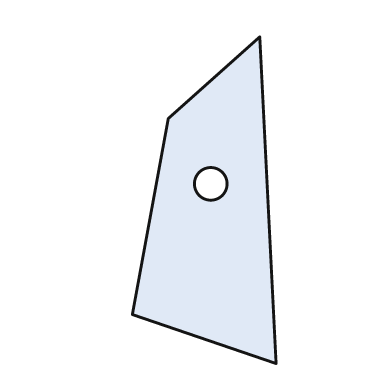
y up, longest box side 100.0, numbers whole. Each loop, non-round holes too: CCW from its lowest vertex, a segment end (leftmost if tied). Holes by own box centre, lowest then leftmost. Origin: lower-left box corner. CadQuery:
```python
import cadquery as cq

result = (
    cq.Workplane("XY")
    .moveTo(44.0, 0.0)
    .lineTo(39.0, 100.0)
    .lineTo(11.0, 75.0)
    .lineTo(0.0, 15.0)
    .close()
    .moveTo(24.0, 55.0)
    .circle(5.0)
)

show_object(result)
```